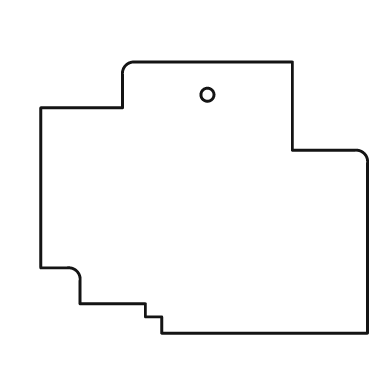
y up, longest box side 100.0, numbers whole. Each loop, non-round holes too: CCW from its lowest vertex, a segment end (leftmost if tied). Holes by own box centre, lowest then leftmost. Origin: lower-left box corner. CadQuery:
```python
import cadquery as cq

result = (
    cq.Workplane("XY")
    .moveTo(37.0, 0.0)
    .lineTo(100.0, 0.0)
    .lineTo(100.0, 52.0)
    .threePointArc((99.0, 55.0), (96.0, 56.0))
    .lineTo(77.0, 56.0)
    .lineTo(77.0, 83.0)
    .lineTo(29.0, 83.0)
    .threePointArc((26.0, 82.0), (25.0, 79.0))
    .lineTo(25.0, 69.0)
    .lineTo(0.0, 69.0)
    .lineTo(0.0, 20.0)
    .lineTo(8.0, 20.0)
    .threePointArc((11.0, 19.0), (12.0, 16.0))
    .lineTo(12.0, 9.0)
    .lineTo(32.0, 9.0)
    .lineTo(32.0, 5.0)
    .lineTo(37.0, 5.0)
    .close()
    .moveTo(51.0, 73.0)
    .circle(2.0)
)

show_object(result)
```